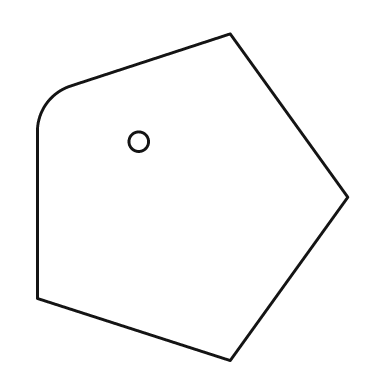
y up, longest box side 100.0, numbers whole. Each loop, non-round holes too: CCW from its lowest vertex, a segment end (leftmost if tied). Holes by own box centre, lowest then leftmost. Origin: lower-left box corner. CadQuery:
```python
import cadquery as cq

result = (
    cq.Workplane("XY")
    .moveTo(59.0, 0.0)
    .lineTo(95.0, 50.0)
    .lineTo(59.0, 100.0)
    .lineTo(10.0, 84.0)
    .threePointArc((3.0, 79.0), (0.0, 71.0))
    .lineTo(0.0, 19.0)
    .close()
    .moveTo(31.0, 67.0)
    .circle(3.0)
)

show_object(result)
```